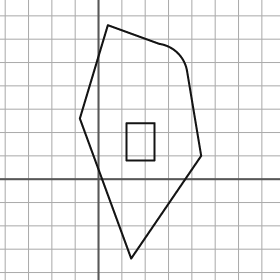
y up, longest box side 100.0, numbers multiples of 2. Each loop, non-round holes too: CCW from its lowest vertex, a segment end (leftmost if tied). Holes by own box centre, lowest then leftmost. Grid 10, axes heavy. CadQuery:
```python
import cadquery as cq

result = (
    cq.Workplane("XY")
    .moveTo(14.0, -34.0)
    .lineTo(44.0, 10.0)
    .lineTo(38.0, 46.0)
    .threePointArc((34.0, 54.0), (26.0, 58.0))
    .lineTo(4.0, 66.0)
    .lineTo(-8.0, 26.0)
    .close()
    .moveTo(12.0, 8.0)
    .lineTo(24.0, 8.0)
    .lineTo(24.0, 24.0)
    .lineTo(12.0, 24.0)
    .close()
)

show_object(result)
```